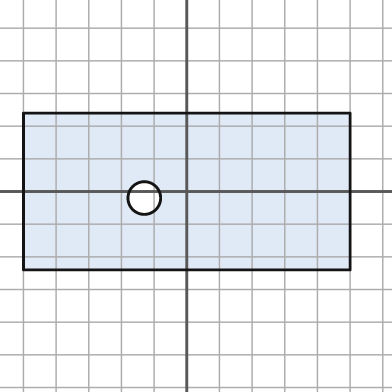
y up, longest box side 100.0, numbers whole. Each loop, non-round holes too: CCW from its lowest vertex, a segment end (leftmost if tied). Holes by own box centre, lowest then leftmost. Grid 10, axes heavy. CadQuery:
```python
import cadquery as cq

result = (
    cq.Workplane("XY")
    .moveTo(-50.0, -24.0)
    .lineTo(50.0, -24.0)
    .lineTo(50.0, 24.0)
    .lineTo(-50.0, 24.0)
    .close()
    .moveTo(-13.0, -2.0)
    .circle(5.0)
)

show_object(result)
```